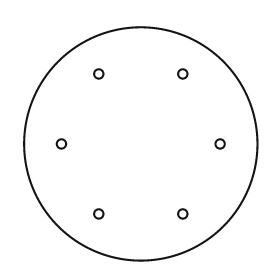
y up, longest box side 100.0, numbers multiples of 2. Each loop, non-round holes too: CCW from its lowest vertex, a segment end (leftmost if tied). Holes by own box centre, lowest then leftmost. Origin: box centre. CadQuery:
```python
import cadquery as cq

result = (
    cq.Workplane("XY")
    .moveTo(0.0, 0.0)
    .circle(50.0)
    .moveTo(-18.0, -30.0)
    .circle(2.0)
    .moveTo(18.0, -30.0)
    .circle(2.0)
    .moveTo(-34.0, 0.0)
    .circle(2.0)
    .moveTo(34.0, 0.0)
    .circle(2.0)
    .moveTo(-18.0, 30.0)
    .circle(2.0)
    .moveTo(18.0, 30.0)
    .circle(2.0)
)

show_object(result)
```